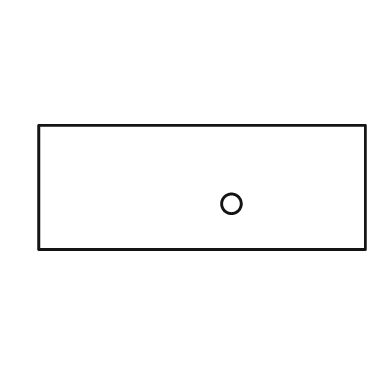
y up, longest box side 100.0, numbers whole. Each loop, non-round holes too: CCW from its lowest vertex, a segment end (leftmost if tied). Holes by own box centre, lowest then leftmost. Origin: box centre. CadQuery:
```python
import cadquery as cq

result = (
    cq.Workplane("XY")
    .moveTo(-50.0, -19.0)
    .lineTo(50.0, -19.0)
    .lineTo(50.0, 19.0)
    .lineTo(-50.0, 19.0)
    .close()
    .moveTo(9.0, -5.0)
    .circle(3.0)
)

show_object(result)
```